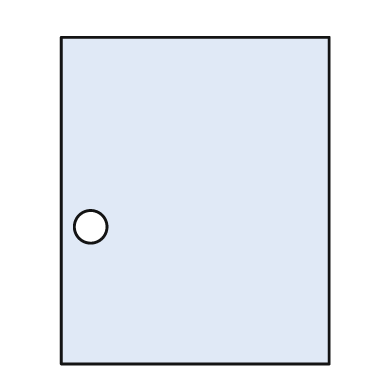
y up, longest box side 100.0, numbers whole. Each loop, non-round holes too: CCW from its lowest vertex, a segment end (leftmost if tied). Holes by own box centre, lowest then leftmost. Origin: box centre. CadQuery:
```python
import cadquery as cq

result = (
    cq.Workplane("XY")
    .moveTo(-41.0, -50.0)
    .lineTo(41.0, -50.0)
    .lineTo(41.0, 50.0)
    .lineTo(-41.0, 50.0)
    .close()
    .moveTo(-32.0, -8.0)
    .circle(5.0)
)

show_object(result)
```